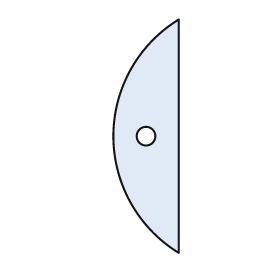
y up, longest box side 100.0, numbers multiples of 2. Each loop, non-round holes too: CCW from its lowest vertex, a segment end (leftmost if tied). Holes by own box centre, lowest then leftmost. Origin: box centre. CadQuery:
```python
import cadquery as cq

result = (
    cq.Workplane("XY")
    .moveTo(14.0, -50.0)
    .lineTo(14.0, 50.0)
    .threePointArc((-14.0, 0.0), (14.0, -50.0))
    .close()
    .moveTo(0.0, 0.0)
    .circle(4.0)
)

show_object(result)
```